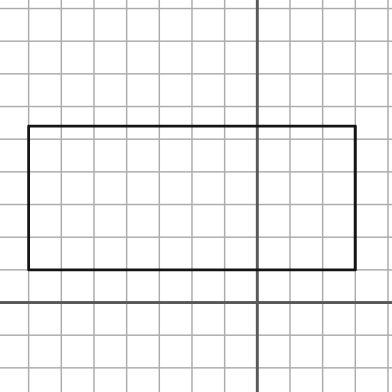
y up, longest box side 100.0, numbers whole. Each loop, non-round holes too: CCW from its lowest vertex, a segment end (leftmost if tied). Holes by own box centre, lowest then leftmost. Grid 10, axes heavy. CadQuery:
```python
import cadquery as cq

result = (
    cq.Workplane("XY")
    .moveTo(-70.0, 10.0)
    .lineTo(30.0, 10.0)
    .lineTo(30.0, 54.0)
    .lineTo(-70.0, 54.0)
    .close()
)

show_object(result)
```